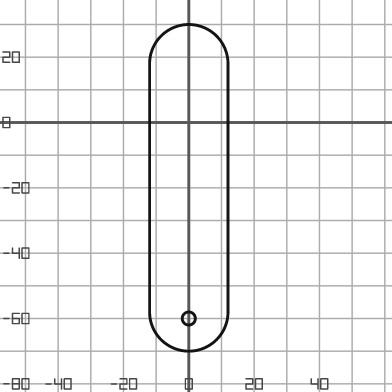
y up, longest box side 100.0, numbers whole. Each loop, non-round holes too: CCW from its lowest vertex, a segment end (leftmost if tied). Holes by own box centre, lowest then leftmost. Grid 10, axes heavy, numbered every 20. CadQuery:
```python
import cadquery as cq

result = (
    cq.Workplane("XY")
    .moveTo(-12.0, -58.0)
    .threePointArc((0.0, -70.0), (12.0, -58.0))
    .lineTo(12.0, 18.0)
    .threePointArc((0.0, 30.0), (-12.0, 18.0))
    .close()
    .moveTo(0.0, -60.0)
    .circle(2.0)
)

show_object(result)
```